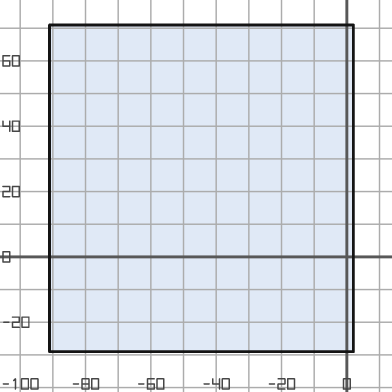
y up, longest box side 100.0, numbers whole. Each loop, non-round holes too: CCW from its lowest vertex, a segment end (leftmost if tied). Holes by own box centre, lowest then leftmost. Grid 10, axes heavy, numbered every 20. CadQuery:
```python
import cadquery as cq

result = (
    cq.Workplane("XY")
    .moveTo(-91.0, -29.0)
    .lineTo(2.0, -29.0)
    .lineTo(2.0, 71.0)
    .lineTo(-91.0, 71.0)
    .close()
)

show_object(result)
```